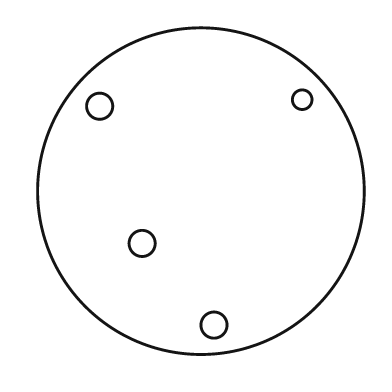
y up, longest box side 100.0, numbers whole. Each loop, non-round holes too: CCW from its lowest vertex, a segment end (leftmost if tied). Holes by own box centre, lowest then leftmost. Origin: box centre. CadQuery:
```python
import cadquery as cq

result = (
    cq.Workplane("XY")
    .moveTo(0.0, 0.0)
    .circle(50.0)
    .moveTo(4.0, -41.0)
    .circle(4.0)
    .moveTo(-18.0, -16.0)
    .circle(4.0)
    .moveTo(-31.0, 26.0)
    .circle(4.0)
    .moveTo(31.0, 28.0)
    .circle(3.0)
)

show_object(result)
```